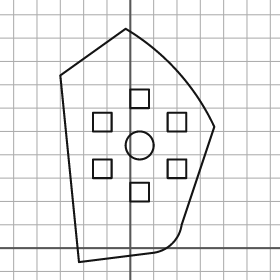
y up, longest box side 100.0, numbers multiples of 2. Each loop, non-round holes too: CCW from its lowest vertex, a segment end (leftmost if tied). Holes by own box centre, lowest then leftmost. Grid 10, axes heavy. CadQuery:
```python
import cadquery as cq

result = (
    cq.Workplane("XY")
    .moveTo(-22.0, -6.0)
    .lineTo(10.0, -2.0)
    .threePointArc((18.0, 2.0), (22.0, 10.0))
    .lineTo(36.0, 52.0)
    .threePointArc((20.0, 76.0), (-2.0, 94.0))
    .lineTo(-30.0, 74.0)
    .close()
    .moveTo(0.0, 20.0)
    .lineTo(8.0, 20.0)
    .lineTo(8.0, 28.0)
    .lineTo(0.0, 28.0)
    .close()
    .moveTo(-16.0, 30.0)
    .lineTo(-8.0, 30.0)
    .lineTo(-8.0, 38.0)
    .lineTo(-16.0, 38.0)
    .close()
    .moveTo(16.0, 30.0)
    .lineTo(24.0, 30.0)
    .lineTo(24.0, 38.0)
    .lineTo(16.0, 38.0)
    .close()
    .moveTo(4.0, 44.0)
    .circle(6.0)
    .moveTo(-16.0, 50.0)
    .lineTo(-8.0, 50.0)
    .lineTo(-8.0, 58.0)
    .lineTo(-16.0, 58.0)
    .close()
    .moveTo(16.0, 50.0)
    .lineTo(24.0, 50.0)
    .lineTo(24.0, 58.0)
    .lineTo(16.0, 58.0)
    .close()
    .moveTo(0.0, 60.0)
    .lineTo(8.0, 60.0)
    .lineTo(8.0, 68.0)
    .lineTo(0.0, 68.0)
    .close()
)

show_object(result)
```